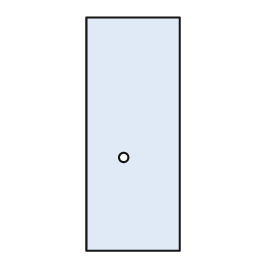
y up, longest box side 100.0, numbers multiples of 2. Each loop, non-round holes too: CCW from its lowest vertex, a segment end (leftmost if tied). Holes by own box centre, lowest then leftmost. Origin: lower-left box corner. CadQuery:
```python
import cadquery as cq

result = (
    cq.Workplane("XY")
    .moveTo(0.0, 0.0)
    .lineTo(40.0, 0.0)
    .lineTo(40.0, 100.0)
    .lineTo(0.0, 100.0)
    .close()
    .moveTo(16.0, 40.0)
    .circle(2.0)
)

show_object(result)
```